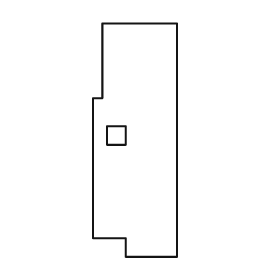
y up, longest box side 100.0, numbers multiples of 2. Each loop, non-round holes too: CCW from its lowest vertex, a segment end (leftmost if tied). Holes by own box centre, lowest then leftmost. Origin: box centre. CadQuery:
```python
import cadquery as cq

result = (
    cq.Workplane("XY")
    .moveTo(-4.0, -50.0)
    .lineTo(18.0, -50.0)
    .lineTo(18.0, 50.0)
    .lineTo(-14.0, 50.0)
    .lineTo(-14.0, 18.0)
    .lineTo(-18.0, 18.0)
    .lineTo(-18.0, -42.0)
    .lineTo(-4.0, -42.0)
    .close()
    .moveTo(-12.0, -2.0)
    .lineTo(-4.0, -2.0)
    .lineTo(-4.0, 6.0)
    .lineTo(-12.0, 6.0)
    .close()
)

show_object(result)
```